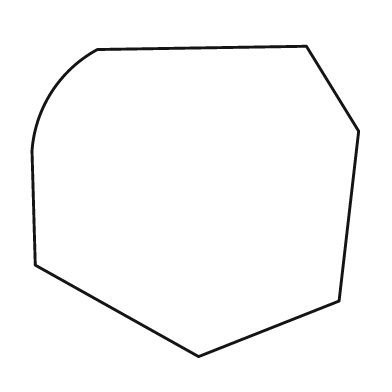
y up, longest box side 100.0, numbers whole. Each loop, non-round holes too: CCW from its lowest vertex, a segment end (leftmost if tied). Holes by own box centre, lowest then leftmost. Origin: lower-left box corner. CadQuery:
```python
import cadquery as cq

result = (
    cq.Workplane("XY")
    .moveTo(51.0, 0.0)
    .lineTo(94.0, 17.0)
    .lineTo(100.0, 69.0)
    .lineTo(84.0, 95.0)
    .lineTo(20.0, 94.0)
    .threePointArc((6.0, 81.0), (0.0, 63.0))
    .lineTo(1.0, 28.0)
    .close()
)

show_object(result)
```